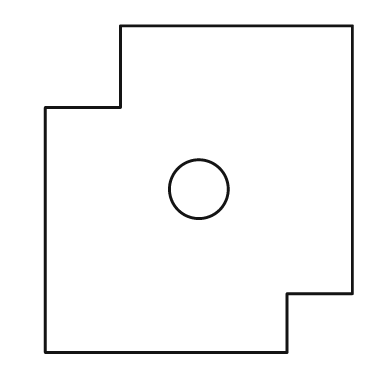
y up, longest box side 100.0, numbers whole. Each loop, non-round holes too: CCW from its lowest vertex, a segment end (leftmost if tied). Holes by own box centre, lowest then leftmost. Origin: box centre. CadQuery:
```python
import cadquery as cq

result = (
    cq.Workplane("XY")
    .moveTo(-47.0, -50.0)
    .lineTo(27.0, -50.0)
    .lineTo(27.0, -32.0)
    .lineTo(47.0, -32.0)
    .lineTo(47.0, 50.0)
    .lineTo(-24.0, 50.0)
    .lineTo(-24.0, 25.0)
    .lineTo(-47.0, 25.0)
    .close()
    .moveTo(0.0, 0.0)
    .circle(9.0)
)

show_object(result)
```